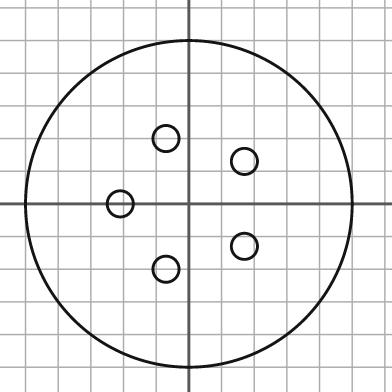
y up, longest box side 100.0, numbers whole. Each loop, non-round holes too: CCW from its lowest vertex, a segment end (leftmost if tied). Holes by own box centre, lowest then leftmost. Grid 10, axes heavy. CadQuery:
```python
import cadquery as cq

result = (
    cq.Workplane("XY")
    .moveTo(0.0, 0.0)
    .circle(50.0)
    .moveTo(-7.0, -20.0)
    .circle(4.0)
    .moveTo(17.0, -13.0)
    .circle(4.0)
    .moveTo(-21.0, 0.0)
    .circle(4.0)
    .moveTo(17.0, 13.0)
    .circle(4.0)
    .moveTo(-7.0, 20.0)
    .circle(4.0)
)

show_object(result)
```